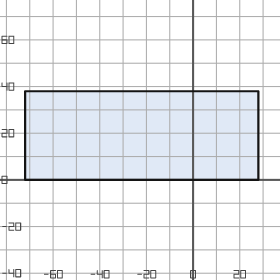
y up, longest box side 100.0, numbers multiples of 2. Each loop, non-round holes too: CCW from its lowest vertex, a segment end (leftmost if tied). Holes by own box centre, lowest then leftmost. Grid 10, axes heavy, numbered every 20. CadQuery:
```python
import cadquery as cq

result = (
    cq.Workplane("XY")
    .moveTo(-72.0, 0.0)
    .lineTo(28.0, 0.0)
    .lineTo(28.0, 38.0)
    .lineTo(-72.0, 38.0)
    .close()
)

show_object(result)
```